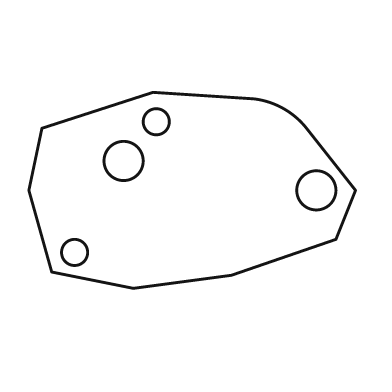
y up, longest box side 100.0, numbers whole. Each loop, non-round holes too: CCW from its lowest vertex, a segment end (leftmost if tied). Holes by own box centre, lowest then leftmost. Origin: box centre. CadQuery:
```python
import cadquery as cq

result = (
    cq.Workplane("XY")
    .moveTo(-18.0, -30.0)
    .lineTo(12.0, -26.0)
    .lineTo(44.0, -15.0)
    .lineTo(50.0, 0.0)
    .lineTo(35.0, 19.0)
    .threePointArc((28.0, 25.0), (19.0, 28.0))
    .lineTo(-12.0, 30.0)
    .lineTo(-46.0, 19.0)
    .lineTo(-50.0, 0.0)
    .lineTo(-43.0, -25.0)
    .close()
    .moveTo(-36.0, -19.0)
    .circle(4.0)
    .moveTo(38.0, 0.0)
    .circle(6.0)
    .moveTo(-21.0, 9.0)
    .circle(6.0)
    .moveTo(-11.0, 21.0)
    .circle(4.0)
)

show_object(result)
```